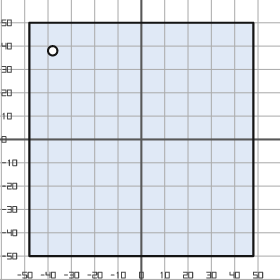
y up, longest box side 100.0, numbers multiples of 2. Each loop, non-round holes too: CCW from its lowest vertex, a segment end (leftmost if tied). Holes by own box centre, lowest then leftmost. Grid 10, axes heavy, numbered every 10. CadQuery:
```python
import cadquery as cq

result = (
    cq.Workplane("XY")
    .moveTo(-48.0, -50.0)
    .lineTo(48.0, -50.0)
    .lineTo(48.0, 50.0)
    .lineTo(-48.0, 50.0)
    .close()
    .moveTo(-38.0, 38.0)
    .circle(2.0)
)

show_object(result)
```